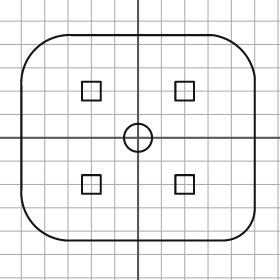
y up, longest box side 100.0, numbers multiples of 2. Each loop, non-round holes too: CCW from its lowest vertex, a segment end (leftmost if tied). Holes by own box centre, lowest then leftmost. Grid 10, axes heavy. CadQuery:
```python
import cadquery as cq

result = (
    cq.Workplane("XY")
    .moveTo(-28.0, -44.0)
    .lineTo(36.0, -44.0)
    .threePointArc((46.0, -40.0), (50.0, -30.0))
    .lineTo(50.0, 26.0)
    .threePointArc((44.0, 38.0), (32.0, 44.0))
    .lineTo(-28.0, 44.0)
    .threePointArc((-44.0, 38.0), (-50.0, 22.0))
    .lineTo(-50.0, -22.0)
    .threePointArc((-44.0, -38.0), (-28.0, -44.0))
    .close()
    .moveTo(-24.0, -24.0)
    .lineTo(-16.0, -24.0)
    .lineTo(-16.0, -16.0)
    .lineTo(-24.0, -16.0)
    .close()
    .moveTo(16.0, -24.0)
    .lineTo(24.0, -24.0)
    .lineTo(24.0, -16.0)
    .lineTo(16.0, -16.0)
    .close()
    .moveTo(0.0, 0.0)
    .circle(6.0)
    .moveTo(-24.0, 16.0)
    .lineTo(-16.0, 16.0)
    .lineTo(-16.0, 24.0)
    .lineTo(-24.0, 24.0)
    .close()
    .moveTo(16.0, 16.0)
    .lineTo(24.0, 16.0)
    .lineTo(24.0, 24.0)
    .lineTo(16.0, 24.0)
    .close()
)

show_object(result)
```